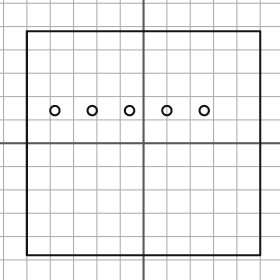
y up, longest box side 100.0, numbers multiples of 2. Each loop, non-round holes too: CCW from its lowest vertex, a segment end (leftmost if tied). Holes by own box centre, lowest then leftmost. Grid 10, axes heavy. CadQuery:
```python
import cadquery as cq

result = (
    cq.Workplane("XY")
    .moveTo(-50.0, -48.0)
    .lineTo(50.0, -48.0)
    .lineTo(50.0, 48.0)
    .lineTo(-50.0, 48.0)
    .close()
    .moveTo(-38.0, 14.0)
    .circle(2.0)
    .moveTo(-22.0, 14.0)
    .circle(2.0)
    .moveTo(-6.0, 14.0)
    .circle(2.0)
    .moveTo(10.0, 14.0)
    .circle(2.0)
    .moveTo(26.0, 14.0)
    .circle(2.0)
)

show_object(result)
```